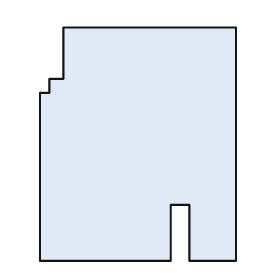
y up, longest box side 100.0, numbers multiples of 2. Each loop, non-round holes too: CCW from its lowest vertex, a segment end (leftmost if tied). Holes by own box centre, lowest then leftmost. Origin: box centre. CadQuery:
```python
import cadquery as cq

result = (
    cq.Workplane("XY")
    .moveTo(-42.0, -50.0)
    .lineTo(14.0, -50.0)
    .lineTo(14.0, -26.0)
    .lineTo(22.0, -26.0)
    .lineTo(22.0, -50.0)
    .lineTo(42.0, -50.0)
    .lineTo(42.0, 50.0)
    .lineTo(-32.0, 50.0)
    .lineTo(-32.0, 28.0)
    .lineTo(-38.0, 28.0)
    .lineTo(-38.0, 22.0)
    .lineTo(-42.0, 22.0)
    .close()
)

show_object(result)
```